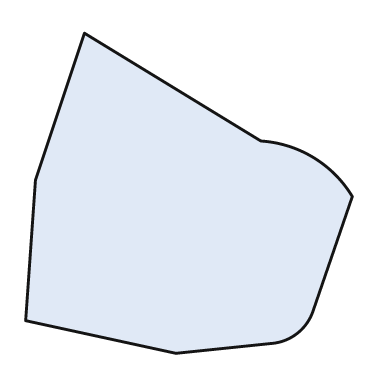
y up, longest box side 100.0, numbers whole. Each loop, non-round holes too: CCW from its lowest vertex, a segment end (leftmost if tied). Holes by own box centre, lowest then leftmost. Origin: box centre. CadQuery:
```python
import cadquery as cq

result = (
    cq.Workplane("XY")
    .moveTo(-4.0, -49.0)
    .lineTo(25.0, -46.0)
    .threePointArc((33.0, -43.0), (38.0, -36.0))
    .lineTo(50.0, -1.0)
    .threePointArc((38.0, 11.0), (22.0, 16.0))
    .lineTo(-32.0, 49.0)
    .lineTo(-47.0, 4.0)
    .lineTo(-50.0, -39.0)
    .close()
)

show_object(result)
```